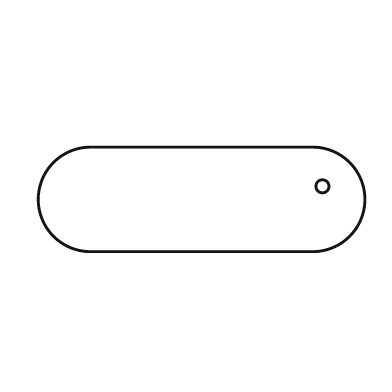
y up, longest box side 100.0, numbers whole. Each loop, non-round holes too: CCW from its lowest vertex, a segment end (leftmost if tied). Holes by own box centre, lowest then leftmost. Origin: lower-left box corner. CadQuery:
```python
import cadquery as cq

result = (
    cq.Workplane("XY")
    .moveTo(16.0, 0.0)
    .lineTo(84.0, 0.0)
    .threePointArc((100.0, 16.0), (84.0, 32.0))
    .lineTo(16.0, 32.0)
    .threePointArc((0.0, 16.0), (16.0, 0.0))
    .close()
    .moveTo(87.0, 20.0)
    .circle(2.0)
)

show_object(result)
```